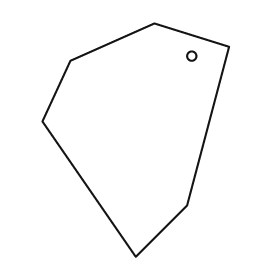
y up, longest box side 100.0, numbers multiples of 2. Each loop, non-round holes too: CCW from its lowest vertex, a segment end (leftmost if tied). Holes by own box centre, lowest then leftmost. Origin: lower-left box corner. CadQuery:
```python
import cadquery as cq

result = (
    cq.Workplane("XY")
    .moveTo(40.0, 0.0)
    .lineTo(62.0, 22.0)
    .lineTo(80.0, 90.0)
    .lineTo(48.0, 100.0)
    .lineTo(12.0, 84.0)
    .lineTo(0.0, 58.0)
    .close()
    .moveTo(64.0, 86.0)
    .circle(2.0)
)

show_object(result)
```